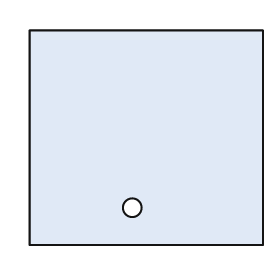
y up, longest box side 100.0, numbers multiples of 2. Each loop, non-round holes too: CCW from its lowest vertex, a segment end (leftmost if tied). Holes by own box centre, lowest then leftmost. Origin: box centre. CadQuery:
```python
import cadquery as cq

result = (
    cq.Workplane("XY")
    .moveTo(-50.0, -46.0)
    .lineTo(50.0, -46.0)
    .lineTo(50.0, 46.0)
    .lineTo(-50.0, 46.0)
    .close()
    .moveTo(-6.0, -30.0)
    .circle(4.0)
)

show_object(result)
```